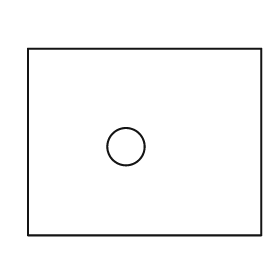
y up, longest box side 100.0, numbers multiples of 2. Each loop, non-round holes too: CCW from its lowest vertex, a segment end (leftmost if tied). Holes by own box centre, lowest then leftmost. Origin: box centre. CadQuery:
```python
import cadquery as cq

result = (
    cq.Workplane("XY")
    .moveTo(-50.0, -40.0)
    .lineTo(50.0, -40.0)
    .lineTo(50.0, 40.0)
    .lineTo(-50.0, 40.0)
    .close()
    .moveTo(-8.0, -2.0)
    .circle(8.0)
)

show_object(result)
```